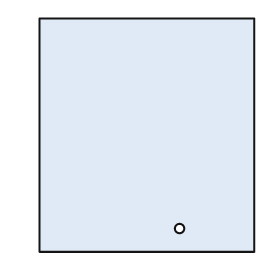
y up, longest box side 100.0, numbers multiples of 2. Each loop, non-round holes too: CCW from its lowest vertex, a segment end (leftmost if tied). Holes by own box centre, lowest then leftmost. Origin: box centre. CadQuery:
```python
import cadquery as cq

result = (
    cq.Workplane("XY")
    .moveTo(-46.0, -50.0)
    .lineTo(46.0, -50.0)
    .lineTo(46.0, 50.0)
    .lineTo(-46.0, 50.0)
    .close()
    .moveTo(14.0, -40.0)
    .circle(2.0)
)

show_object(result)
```